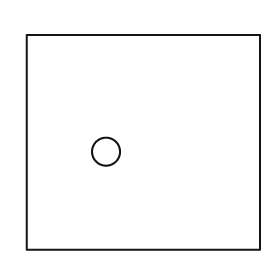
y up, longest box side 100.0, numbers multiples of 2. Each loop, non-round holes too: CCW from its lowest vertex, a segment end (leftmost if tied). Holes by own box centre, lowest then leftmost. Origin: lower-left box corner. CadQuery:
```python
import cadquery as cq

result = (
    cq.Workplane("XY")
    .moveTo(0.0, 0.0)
    .lineTo(100.0, 0.0)
    .lineTo(100.0, 92.0)
    .lineTo(0.0, 92.0)
    .close()
    .moveTo(34.0, 42.0)
    .circle(6.0)
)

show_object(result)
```